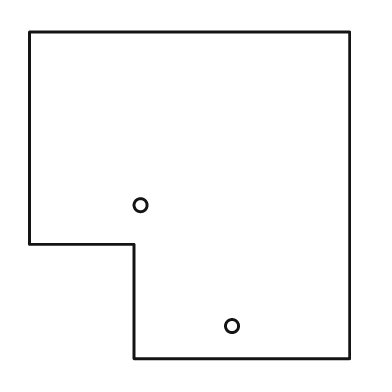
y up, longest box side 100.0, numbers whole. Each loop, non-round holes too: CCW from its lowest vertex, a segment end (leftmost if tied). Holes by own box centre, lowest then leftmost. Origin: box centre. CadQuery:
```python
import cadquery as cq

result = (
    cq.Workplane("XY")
    .moveTo(-17.0, -50.0)
    .lineTo(49.0, -50.0)
    .lineTo(49.0, 50.0)
    .lineTo(-49.0, 50.0)
    .lineTo(-49.0, -15.0)
    .lineTo(-17.0, -15.0)
    .close()
    .moveTo(13.0, -40.0)
    .circle(2.0)
    .moveTo(-15.0, -3.0)
    .circle(2.0)
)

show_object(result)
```